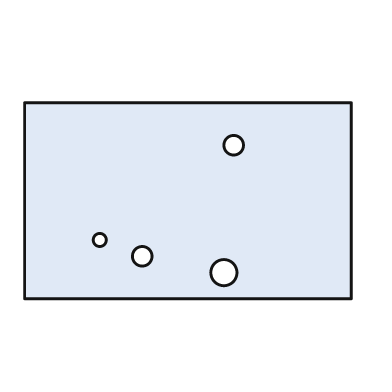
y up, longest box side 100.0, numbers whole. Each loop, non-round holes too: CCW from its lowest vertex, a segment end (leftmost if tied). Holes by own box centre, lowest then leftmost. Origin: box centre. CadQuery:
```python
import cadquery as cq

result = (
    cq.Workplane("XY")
    .moveTo(-50.0, -30.0)
    .lineTo(50.0, -30.0)
    .lineTo(50.0, 30.0)
    .lineTo(-50.0, 30.0)
    .close()
    .moveTo(11.0, -22.0)
    .circle(4.0)
    .moveTo(-14.0, -17.0)
    .circle(3.0)
    .moveTo(-27.0, -12.0)
    .circle(2.0)
    .moveTo(14.0, 17.0)
    .circle(3.0)
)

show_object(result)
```